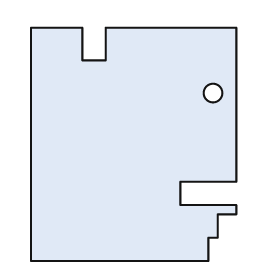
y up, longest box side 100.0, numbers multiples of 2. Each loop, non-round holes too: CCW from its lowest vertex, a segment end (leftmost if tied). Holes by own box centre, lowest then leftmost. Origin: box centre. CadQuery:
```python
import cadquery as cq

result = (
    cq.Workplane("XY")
    .moveTo(-44.0, -50.0)
    .lineTo(32.0, -50.0)
    .lineTo(32.0, -40.0)
    .lineTo(36.0, -40.0)
    .lineTo(36.0, -30.0)
    .lineTo(44.0, -30.0)
    .lineTo(44.0, -26.0)
    .lineTo(20.0, -26.0)
    .lineTo(20.0, -16.0)
    .lineTo(44.0, -16.0)
    .lineTo(44.0, 50.0)
    .lineTo(-12.0, 50.0)
    .lineTo(-12.0, 36.0)
    .lineTo(-22.0, 36.0)
    .lineTo(-22.0, 50.0)
    .lineTo(-44.0, 50.0)
    .close()
    .moveTo(34.0, 22.0)
    .circle(4.0)
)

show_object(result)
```